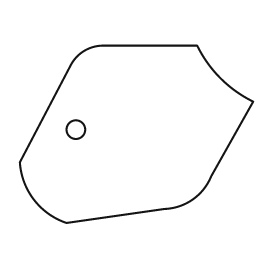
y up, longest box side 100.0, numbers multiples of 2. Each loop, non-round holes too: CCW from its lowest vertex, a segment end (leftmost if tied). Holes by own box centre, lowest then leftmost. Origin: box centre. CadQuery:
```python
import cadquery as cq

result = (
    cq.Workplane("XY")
    .moveTo(-30.0, -38.0)
    .lineTo(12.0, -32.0)
    .threePointArc((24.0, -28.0), (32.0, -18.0))
    .lineTo(50.0, 14.0)
    .threePointArc((36.0, 24.0), (26.0, 38.0))
    .lineTo(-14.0, 38.0)
    .threePointArc((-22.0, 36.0), (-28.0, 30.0))
    .lineTo(-50.0, -12.0)
    .threePointArc((-44.0, -28.0), (-30.0, -38.0))
    .close()
    .moveTo(-26.0, 2.0)
    .circle(4.0)
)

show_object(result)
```